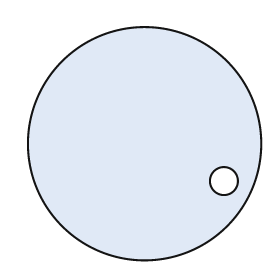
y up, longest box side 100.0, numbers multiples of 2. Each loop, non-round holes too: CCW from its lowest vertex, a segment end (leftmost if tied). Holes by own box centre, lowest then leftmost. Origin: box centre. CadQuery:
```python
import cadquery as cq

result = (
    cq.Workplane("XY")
    .moveTo(0.0, 0.0)
    .circle(50.0)
    .moveTo(34.0, -16.0)
    .circle(6.0)
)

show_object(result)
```